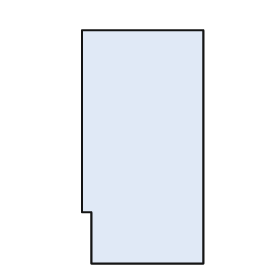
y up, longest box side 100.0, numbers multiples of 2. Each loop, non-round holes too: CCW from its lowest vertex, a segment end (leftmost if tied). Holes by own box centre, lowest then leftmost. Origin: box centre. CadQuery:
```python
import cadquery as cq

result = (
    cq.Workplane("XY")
    .moveTo(-22.0, -50.0)
    .lineTo(26.0, -50.0)
    .lineTo(26.0, 50.0)
    .lineTo(-26.0, 50.0)
    .lineTo(-26.0, -28.0)
    .lineTo(-22.0, -28.0)
    .close()
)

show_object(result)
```